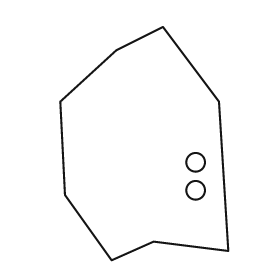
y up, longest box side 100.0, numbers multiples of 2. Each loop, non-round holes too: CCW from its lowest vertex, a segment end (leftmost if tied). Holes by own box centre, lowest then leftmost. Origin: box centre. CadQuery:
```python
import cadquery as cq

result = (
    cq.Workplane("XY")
    .moveTo(-14.0, -50.0)
    .lineTo(4.0, -42.0)
    .lineTo(36.0, -46.0)
    .lineTo(32.0, 18.0)
    .lineTo(8.0, 50.0)
    .lineTo(-12.0, 40.0)
    .lineTo(-36.0, 18.0)
    .lineTo(-34.0, -22.0)
    .close()
    .moveTo(22.0, -20.0)
    .circle(4.0)
    .moveTo(22.0, -8.0)
    .circle(4.0)
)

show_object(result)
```